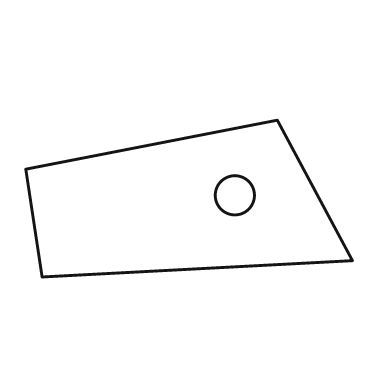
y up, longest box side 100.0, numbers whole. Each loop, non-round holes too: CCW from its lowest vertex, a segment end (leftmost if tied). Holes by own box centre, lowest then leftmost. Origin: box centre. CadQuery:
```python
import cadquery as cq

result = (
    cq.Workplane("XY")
    .moveTo(-45.0, -24.0)
    .lineTo(50.0, -19.0)
    .lineTo(27.0, 24.0)
    .lineTo(-50.0, 9.0)
    .close()
    .moveTo(14.0, 1.0)
    .circle(6.0)
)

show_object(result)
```